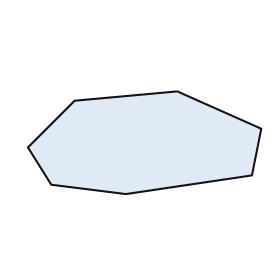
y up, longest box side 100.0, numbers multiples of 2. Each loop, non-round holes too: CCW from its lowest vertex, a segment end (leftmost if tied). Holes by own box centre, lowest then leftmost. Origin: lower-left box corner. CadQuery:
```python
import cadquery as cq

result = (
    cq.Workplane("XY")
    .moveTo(42.0, 0.0)
    .lineTo(96.0, 8.0)
    .lineTo(100.0, 28.0)
    .lineTo(64.0, 44.0)
    .lineTo(20.0, 40.0)
    .lineTo(0.0, 20.0)
    .lineTo(10.0, 4.0)
    .close()
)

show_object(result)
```